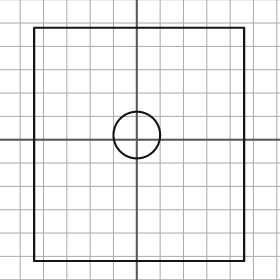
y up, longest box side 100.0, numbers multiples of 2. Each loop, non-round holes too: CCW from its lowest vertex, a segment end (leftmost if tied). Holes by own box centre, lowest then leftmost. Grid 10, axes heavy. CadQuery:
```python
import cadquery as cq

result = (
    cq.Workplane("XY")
    .moveTo(-44.0, -52.0)
    .lineTo(46.0, -52.0)
    .lineTo(46.0, 48.0)
    .lineTo(-44.0, 48.0)
    .close()
    .moveTo(0.0, 2.0)
    .circle(10.0)
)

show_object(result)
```